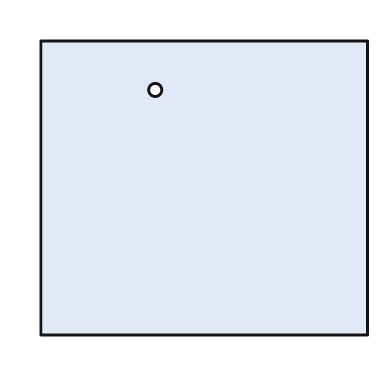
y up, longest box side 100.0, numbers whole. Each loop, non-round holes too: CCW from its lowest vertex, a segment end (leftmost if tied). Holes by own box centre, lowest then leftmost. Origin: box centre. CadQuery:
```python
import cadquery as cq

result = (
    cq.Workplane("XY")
    .moveTo(-50.0, -45.0)
    .lineTo(50.0, -45.0)
    .lineTo(50.0, 45.0)
    .lineTo(-50.0, 45.0)
    .close()
    .moveTo(-15.0, 30.0)
    .circle(2.0)
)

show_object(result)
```